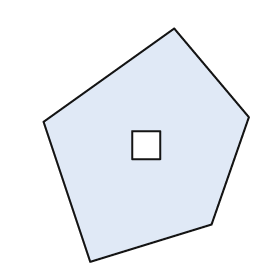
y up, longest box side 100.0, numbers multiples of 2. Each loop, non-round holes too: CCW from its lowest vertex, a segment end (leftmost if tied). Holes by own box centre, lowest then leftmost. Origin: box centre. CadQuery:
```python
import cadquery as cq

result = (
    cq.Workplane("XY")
    .moveTo(-24.0, -50.0)
    .lineTo(28.0, -34.0)
    .lineTo(44.0, 12.0)
    .lineTo(12.0, 50.0)
    .lineTo(-44.0, 10.0)
    .close()
    .moveTo(-6.0, -6.0)
    .lineTo(6.0, -6.0)
    .lineTo(6.0, 6.0)
    .lineTo(-6.0, 6.0)
    .close()
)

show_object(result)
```